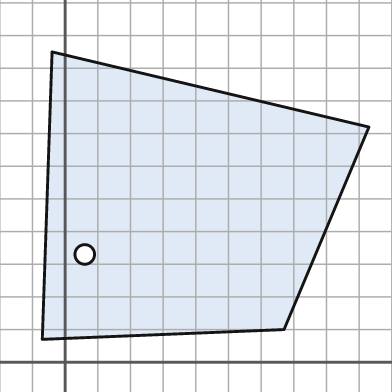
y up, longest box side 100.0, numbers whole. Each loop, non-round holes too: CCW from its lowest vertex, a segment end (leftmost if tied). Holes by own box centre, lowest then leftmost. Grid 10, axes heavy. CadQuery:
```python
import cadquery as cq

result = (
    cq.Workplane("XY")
    .moveTo(-7.0, 7.0)
    .lineTo(67.0, 10.0)
    .lineTo(93.0, 72.0)
    .lineTo(-4.0, 95.0)
    .close()
    .moveTo(6.0, 33.0)
    .circle(3.0)
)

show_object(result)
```